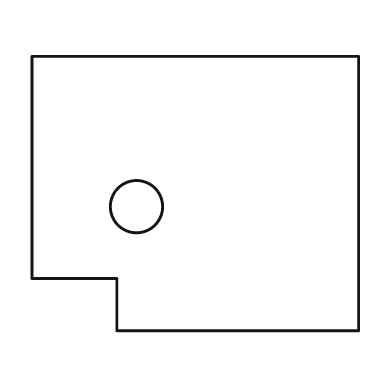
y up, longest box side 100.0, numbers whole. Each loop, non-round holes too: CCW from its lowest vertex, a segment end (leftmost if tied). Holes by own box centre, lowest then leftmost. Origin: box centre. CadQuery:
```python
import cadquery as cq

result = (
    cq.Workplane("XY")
    .moveTo(-24.0, -42.0)
    .lineTo(50.0, -42.0)
    .lineTo(50.0, 42.0)
    .lineTo(-50.0, 42.0)
    .lineTo(-50.0, -26.0)
    .lineTo(-24.0, -26.0)
    .close()
    .moveTo(-18.0, -4.0)
    .circle(8.0)
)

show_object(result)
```